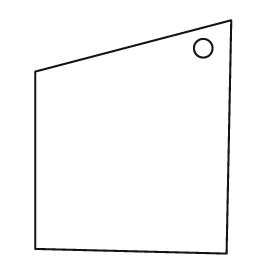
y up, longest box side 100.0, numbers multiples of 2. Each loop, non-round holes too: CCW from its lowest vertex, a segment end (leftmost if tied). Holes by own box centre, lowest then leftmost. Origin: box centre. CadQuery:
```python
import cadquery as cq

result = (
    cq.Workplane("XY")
    .moveTo(40.0, -50.0)
    .lineTo(42.0, 50.0)
    .lineTo(-42.0, 28.0)
    .lineTo(-42.0, -48.0)
    .close()
    .moveTo(30.0, 38.0)
    .circle(4.0)
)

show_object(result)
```